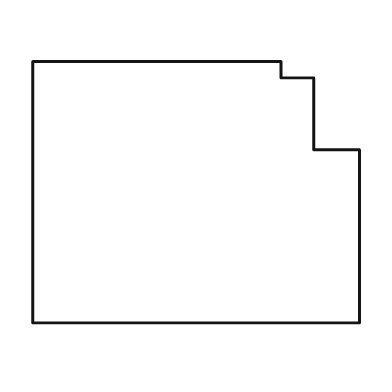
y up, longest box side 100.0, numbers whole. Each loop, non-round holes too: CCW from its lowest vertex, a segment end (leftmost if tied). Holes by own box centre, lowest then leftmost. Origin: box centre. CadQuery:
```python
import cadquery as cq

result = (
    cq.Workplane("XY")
    .moveTo(-50.0, -40.0)
    .lineTo(50.0, -40.0)
    .lineTo(50.0, 13.0)
    .lineTo(36.0, 13.0)
    .lineTo(36.0, 35.0)
    .lineTo(26.0, 35.0)
    .lineTo(26.0, 40.0)
    .lineTo(-50.0, 40.0)
    .close()
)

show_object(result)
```